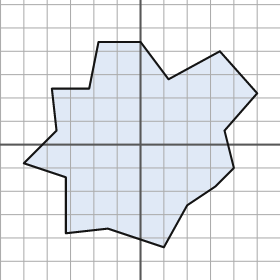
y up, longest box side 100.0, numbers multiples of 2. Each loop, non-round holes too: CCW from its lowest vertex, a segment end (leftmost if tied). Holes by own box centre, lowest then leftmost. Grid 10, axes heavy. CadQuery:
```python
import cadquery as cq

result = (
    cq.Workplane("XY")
    .moveTo(10.0, -44.0)
    .lineTo(20.0, -26.0)
    .lineTo(32.0, -18.0)
    .lineTo(40.0, -10.0)
    .lineTo(36.0, 6.0)
    .lineTo(50.0, 22.0)
    .lineTo(34.0, 40.0)
    .lineTo(12.0, 28.0)
    .lineTo(0.0, 44.0)
    .lineTo(-18.0, 44.0)
    .lineTo(-22.0, 24.0)
    .lineTo(-38.0, 24.0)
    .lineTo(-36.0, 6.0)
    .lineTo(-50.0, -8.0)
    .lineTo(-32.0, -14.0)
    .lineTo(-32.0, -38.0)
    .lineTo(-14.0, -36.0)
    .close()
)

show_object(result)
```